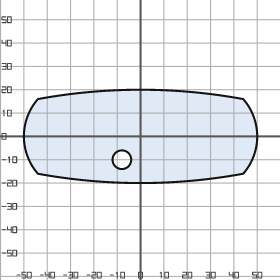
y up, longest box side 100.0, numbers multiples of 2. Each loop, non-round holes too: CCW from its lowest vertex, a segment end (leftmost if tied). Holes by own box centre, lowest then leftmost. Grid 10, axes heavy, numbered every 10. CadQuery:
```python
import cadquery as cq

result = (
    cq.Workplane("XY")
    .moveTo(-44.0, -16.0)
    .threePointArc((0.0, -20.0), (44.0, -16.0))
    .threePointArc((50.0, 0.0), (44.0, 16.0))
    .threePointArc((0.0, 20.0), (-44.0, 16.0))
    .threePointArc((-50.0, 0.0), (-44.0, -16.0))
    .close()
    .moveTo(-8.0, -10.0)
    .circle(4.0)
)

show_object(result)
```